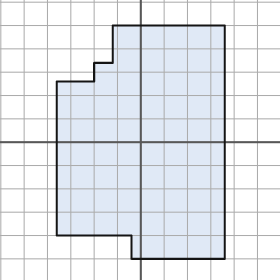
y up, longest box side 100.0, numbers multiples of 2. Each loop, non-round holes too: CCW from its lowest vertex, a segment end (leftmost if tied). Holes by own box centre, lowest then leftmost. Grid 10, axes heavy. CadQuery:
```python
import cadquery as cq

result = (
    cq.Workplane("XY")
    .moveTo(-4.0, -50.0)
    .lineTo(36.0, -50.0)
    .lineTo(36.0, 50.0)
    .lineTo(-12.0, 50.0)
    .lineTo(-12.0, 34.0)
    .lineTo(-20.0, 34.0)
    .lineTo(-20.0, 26.0)
    .lineTo(-36.0, 26.0)
    .lineTo(-36.0, -40.0)
    .lineTo(-4.0, -40.0)
    .close()
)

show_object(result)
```